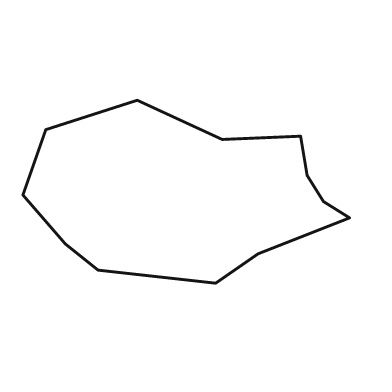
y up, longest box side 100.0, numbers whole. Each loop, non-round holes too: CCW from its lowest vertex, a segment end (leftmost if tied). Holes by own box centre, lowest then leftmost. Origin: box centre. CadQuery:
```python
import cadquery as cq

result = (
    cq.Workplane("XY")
    .moveTo(9.0, -28.0)
    .lineTo(22.0, -19.0)
    .lineTo(50.0, -8.0)
    .lineTo(42.0, -3.0)
    .lineTo(37.0, 5.0)
    .lineTo(35.0, 17.0)
    .lineTo(11.0, 16.0)
    .lineTo(-15.0, 28.0)
    .lineTo(-43.0, 19.0)
    .lineTo(-50.0, -1.0)
    .lineTo(-37.0, -16.0)
    .lineTo(-27.0, -24.0)
    .close()
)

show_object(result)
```